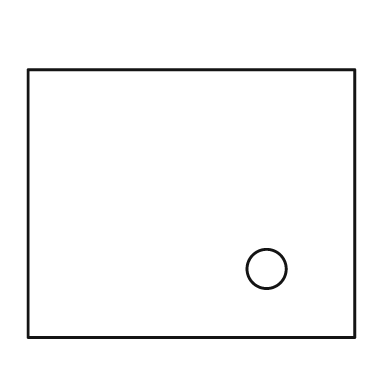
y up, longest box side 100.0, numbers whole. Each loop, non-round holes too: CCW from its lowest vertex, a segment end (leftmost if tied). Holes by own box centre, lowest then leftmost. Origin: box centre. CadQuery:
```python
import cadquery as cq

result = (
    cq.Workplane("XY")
    .moveTo(-50.0, -41.0)
    .lineTo(50.0, -41.0)
    .lineTo(50.0, 41.0)
    .lineTo(-50.0, 41.0)
    .close()
    .moveTo(23.0, -20.0)
    .circle(6.0)
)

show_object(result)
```